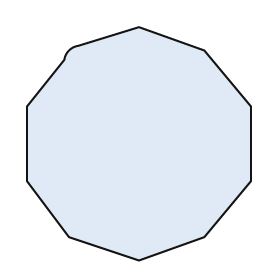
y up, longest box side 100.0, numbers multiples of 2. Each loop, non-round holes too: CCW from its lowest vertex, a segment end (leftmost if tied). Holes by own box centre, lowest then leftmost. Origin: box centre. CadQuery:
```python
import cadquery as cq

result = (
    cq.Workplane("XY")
    .moveTo(0.0, -50.0)
    .lineTo(28.0, -40.0)
    .lineTo(48.0, -16.0)
    .lineTo(48.0, 16.0)
    .lineTo(28.0, 40.0)
    .lineTo(0.0, 50.0)
    .lineTo(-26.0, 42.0)
    .threePointArc((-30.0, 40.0), (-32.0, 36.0))
    .lineTo(-48.0, 16.0)
    .lineTo(-48.0, -16.0)
    .lineTo(-30.0, -40.0)
    .close()
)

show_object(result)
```